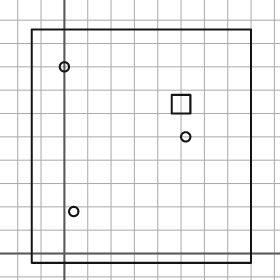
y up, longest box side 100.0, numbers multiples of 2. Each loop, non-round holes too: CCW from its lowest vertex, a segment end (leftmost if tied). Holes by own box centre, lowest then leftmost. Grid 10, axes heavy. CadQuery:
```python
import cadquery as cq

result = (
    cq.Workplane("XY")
    .moveTo(-14.0, -4.0)
    .lineTo(80.0, -4.0)
    .lineTo(80.0, 96.0)
    .lineTo(-14.0, 96.0)
    .close()
    .moveTo(4.0, 18.0)
    .circle(2.0)
    .moveTo(52.0, 50.0)
    .circle(2.0)
    .moveTo(46.0, 60.0)
    .lineTo(54.0, 60.0)
    .lineTo(54.0, 68.0)
    .lineTo(46.0, 68.0)
    .close()
    .moveTo(0.0, 80.0)
    .circle(2.0)
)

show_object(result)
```